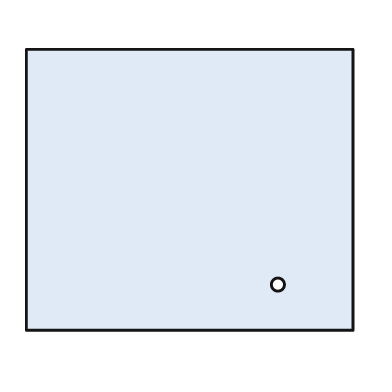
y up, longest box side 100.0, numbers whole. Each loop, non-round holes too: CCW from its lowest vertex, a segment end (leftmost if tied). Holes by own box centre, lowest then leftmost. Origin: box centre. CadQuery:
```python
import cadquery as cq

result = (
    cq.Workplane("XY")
    .moveTo(-50.0, -43.0)
    .lineTo(50.0, -43.0)
    .lineTo(50.0, 43.0)
    .lineTo(-50.0, 43.0)
    .close()
    .moveTo(27.0, -29.0)
    .circle(2.0)
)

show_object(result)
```